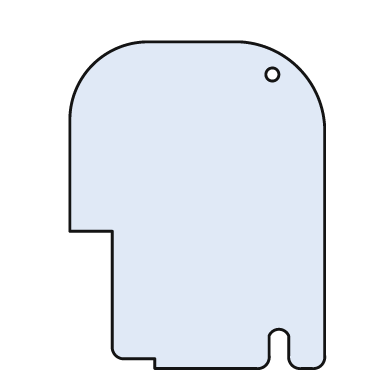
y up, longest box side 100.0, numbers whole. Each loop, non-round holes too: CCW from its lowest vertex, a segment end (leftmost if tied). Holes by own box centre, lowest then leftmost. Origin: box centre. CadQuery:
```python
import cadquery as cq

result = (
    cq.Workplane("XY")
    .moveTo(-13.0, -50.0)
    .lineTo(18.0, -50.0)
    .threePointArc((21.0, -49.0), (22.0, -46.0))
    .lineTo(22.0, -40.0)
    .threePointArc((25.0, -38.0), (28.0, -40.0))
    .lineTo(28.0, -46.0)
    .threePointArc((29.0, -49.0), (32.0, -50.0))
    .lineTo(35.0, -50.0)
    .threePointArc((38.0, -49.0), (39.0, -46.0))
    .lineTo(39.0, 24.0)
    .threePointArc((31.0, 42.0), (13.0, 50.0))
    .lineTo(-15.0, 50.0)
    .threePointArc((-32.0, 43.0), (-39.0, 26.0))
    .lineTo(-39.0, -8.0)
    .lineTo(-26.0, -8.0)
    .lineTo(-26.0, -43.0)
    .threePointArc((-25.0, -46.0), (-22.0, -47.0))
    .lineTo(-13.0, -47.0)
    .close()
    .moveTo(23.0, 40.0)
    .circle(2.0)
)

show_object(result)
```